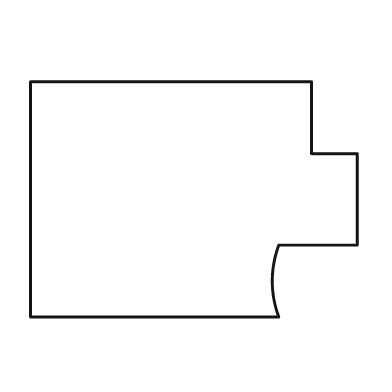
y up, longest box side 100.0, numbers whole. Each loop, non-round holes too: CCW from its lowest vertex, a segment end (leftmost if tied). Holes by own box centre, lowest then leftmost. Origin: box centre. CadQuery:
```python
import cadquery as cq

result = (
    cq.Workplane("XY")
    .moveTo(-50.0, -36.0)
    .lineTo(26.0, -36.0)
    .threePointArc((24.0, -25.0), (26.0, -14.0))
    .lineTo(50.0, -14.0)
    .lineTo(50.0, 14.0)
    .lineTo(36.0, 14.0)
    .lineTo(36.0, 36.0)
    .lineTo(-50.0, 36.0)
    .close()
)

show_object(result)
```